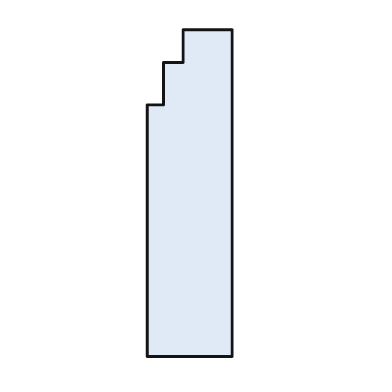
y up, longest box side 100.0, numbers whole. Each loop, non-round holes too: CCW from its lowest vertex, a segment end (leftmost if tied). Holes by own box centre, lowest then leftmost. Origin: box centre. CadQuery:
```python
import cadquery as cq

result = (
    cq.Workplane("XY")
    .moveTo(-13.0, -50.0)
    .lineTo(13.0, -50.0)
    .lineTo(13.0, 50.0)
    .lineTo(-2.0, 50.0)
    .lineTo(-2.0, 40.0)
    .lineTo(-8.0, 40.0)
    .lineTo(-8.0, 27.0)
    .lineTo(-13.0, 27.0)
    .close()
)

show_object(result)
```